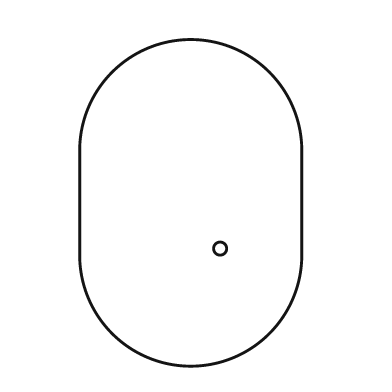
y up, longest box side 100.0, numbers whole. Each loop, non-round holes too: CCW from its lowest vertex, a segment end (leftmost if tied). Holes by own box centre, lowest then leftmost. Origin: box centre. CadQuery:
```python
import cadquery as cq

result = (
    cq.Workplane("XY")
    .moveTo(-34.0, -16.0)
    .threePointArc((0.0, -50.0), (34.0, -16.0))
    .lineTo(34.0, 16.0)
    .threePointArc((0.0, 50.0), (-34.0, 16.0))
    .close()
    .moveTo(9.0, -14.0)
    .circle(2.0)
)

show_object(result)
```